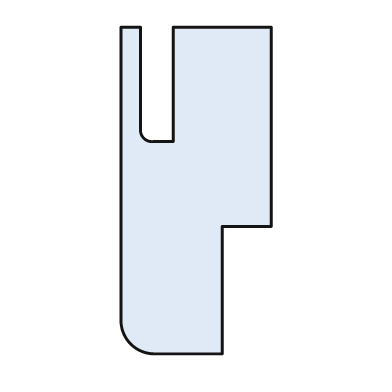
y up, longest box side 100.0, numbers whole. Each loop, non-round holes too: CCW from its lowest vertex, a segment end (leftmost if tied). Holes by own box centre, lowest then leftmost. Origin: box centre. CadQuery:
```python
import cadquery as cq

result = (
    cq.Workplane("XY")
    .moveTo(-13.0, -50.0)
    .lineTo(8.0, -50.0)
    .lineTo(8.0, -11.0)
    .lineTo(23.0, -11.0)
    .lineTo(23.0, 50.0)
    .lineTo(-7.0, 50.0)
    .lineTo(-7.0, 15.0)
    .lineTo(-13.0, 15.0)
    .threePointArc((-16.0, 16.0), (-17.0, 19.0))
    .lineTo(-17.0, 50.0)
    .lineTo(-23.0, 50.0)
    .lineTo(-23.0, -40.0)
    .threePointArc((-20.0, -47.0), (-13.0, -50.0))
    .close()
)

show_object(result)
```